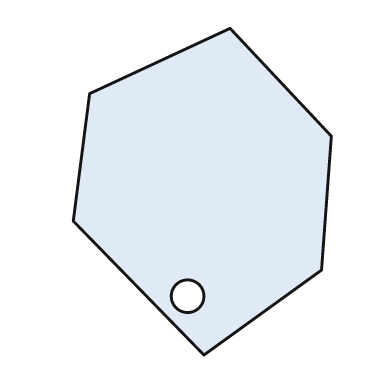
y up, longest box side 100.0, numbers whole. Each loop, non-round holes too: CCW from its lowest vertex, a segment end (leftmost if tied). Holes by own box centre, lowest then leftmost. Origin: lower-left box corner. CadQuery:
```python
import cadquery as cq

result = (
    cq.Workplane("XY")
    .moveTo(40.0, 0.0)
    .lineTo(76.0, 26.0)
    .lineTo(79.0, 67.0)
    .lineTo(48.0, 100.0)
    .lineTo(5.0, 80.0)
    .lineTo(0.0, 41.0)
    .close()
    .moveTo(35.0, 18.0)
    .circle(5.0)
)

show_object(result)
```